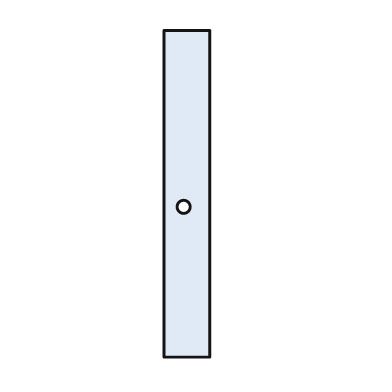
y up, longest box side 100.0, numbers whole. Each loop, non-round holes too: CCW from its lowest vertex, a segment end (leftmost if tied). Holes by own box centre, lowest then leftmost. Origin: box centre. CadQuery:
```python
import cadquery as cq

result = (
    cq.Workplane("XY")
    .moveTo(-7.0, -50.0)
    .lineTo(7.0, -50.0)
    .lineTo(7.0, 50.0)
    .lineTo(-7.0, 50.0)
    .close()
    .moveTo(-1.0, -4.0)
    .circle(2.0)
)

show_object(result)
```